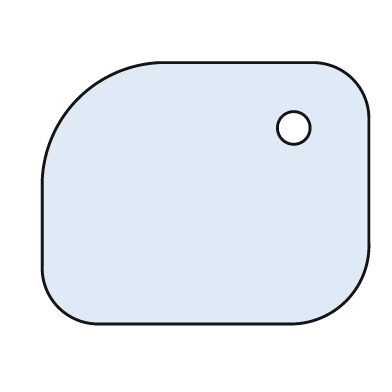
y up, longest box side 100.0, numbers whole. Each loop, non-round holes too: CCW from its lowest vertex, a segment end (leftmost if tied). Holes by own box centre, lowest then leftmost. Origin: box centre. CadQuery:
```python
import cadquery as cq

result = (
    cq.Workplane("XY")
    .moveTo(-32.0, -40.0)
    .lineTo(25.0, -40.0)
    .threePointArc((43.0, -33.0), (50.0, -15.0))
    .lineTo(50.0, 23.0)
    .threePointArc((45.0, 35.0), (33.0, 40.0))
    .lineTo(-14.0, 40.0)
    .threePointArc((-39.0, 29.0), (-50.0, 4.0))
    .lineTo(-50.0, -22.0)
    .threePointArc((-45.0, -35.0), (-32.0, -40.0))
    .close()
    .moveTo(27.0, 20.0)
    .circle(5.0)
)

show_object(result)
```